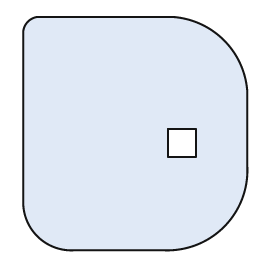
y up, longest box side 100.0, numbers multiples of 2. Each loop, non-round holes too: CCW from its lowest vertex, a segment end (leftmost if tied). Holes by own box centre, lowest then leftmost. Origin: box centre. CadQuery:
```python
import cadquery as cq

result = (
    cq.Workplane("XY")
    .moveTo(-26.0, -50.0)
    .lineTo(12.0, -50.0)
    .threePointArc((38.0, -40.0), (48.0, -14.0))
    .lineTo(48.0, 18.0)
    .threePointArc((38.0, 40.0), (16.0, 50.0))
    .lineTo(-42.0, 50.0)
    .threePointArc((-46.0, 48.0), (-48.0, 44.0))
    .lineTo(-48.0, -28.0)
    .threePointArc((-42.0, -44.0), (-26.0, -50.0))
    .close()
    .moveTo(14.0, -10.0)
    .lineTo(26.0, -10.0)
    .lineTo(26.0, 2.0)
    .lineTo(14.0, 2.0)
    .close()
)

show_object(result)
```